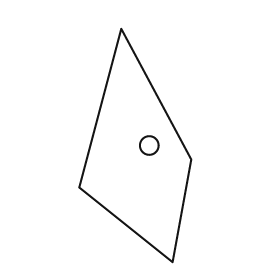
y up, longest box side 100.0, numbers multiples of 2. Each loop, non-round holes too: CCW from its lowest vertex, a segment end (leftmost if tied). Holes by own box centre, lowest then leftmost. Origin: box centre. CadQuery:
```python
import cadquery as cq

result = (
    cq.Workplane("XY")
    .moveTo(16.0, -50.0)
    .lineTo(24.0, -6.0)
    .lineTo(-6.0, 50.0)
    .lineTo(-24.0, -18.0)
    .close()
    .moveTo(6.0, 0.0)
    .circle(4.0)
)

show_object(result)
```